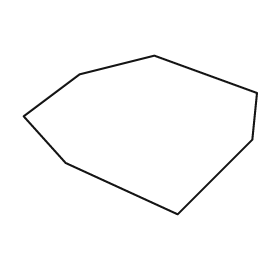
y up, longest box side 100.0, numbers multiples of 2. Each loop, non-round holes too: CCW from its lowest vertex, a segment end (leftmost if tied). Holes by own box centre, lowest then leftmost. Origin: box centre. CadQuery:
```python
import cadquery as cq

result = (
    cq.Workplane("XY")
    .moveTo(16.0, -34.0)
    .lineTo(48.0, -2.0)
    .lineTo(50.0, 18.0)
    .lineTo(6.0, 34.0)
    .lineTo(-26.0, 26.0)
    .lineTo(-50.0, 8.0)
    .lineTo(-32.0, -12.0)
    .close()
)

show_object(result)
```